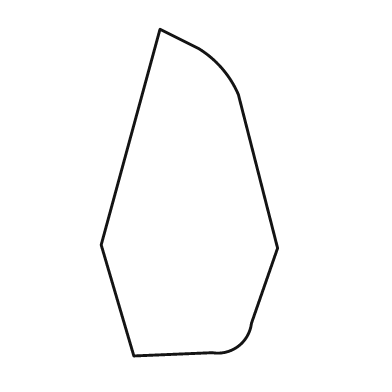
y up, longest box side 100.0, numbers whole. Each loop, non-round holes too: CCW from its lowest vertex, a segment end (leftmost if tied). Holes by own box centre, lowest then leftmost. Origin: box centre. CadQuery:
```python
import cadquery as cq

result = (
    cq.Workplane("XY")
    .moveTo(-17.0, -50.0)
    .lineTo(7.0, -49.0)
    .threePointArc((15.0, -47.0), (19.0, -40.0))
    .lineTo(27.0, -17.0)
    .lineTo(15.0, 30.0)
    .threePointArc((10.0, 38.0), (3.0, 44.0))
    .lineTo(-9.0, 50.0)
    .lineTo(-27.0, -16.0)
    .close()
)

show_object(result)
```